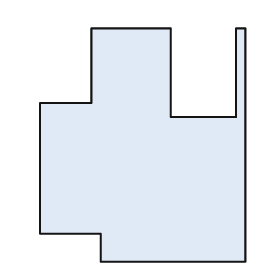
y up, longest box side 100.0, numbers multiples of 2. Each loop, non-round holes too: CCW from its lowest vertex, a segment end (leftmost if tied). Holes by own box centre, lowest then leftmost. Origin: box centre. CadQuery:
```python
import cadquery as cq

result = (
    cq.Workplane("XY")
    .moveTo(-18.0, -50.0)
    .lineTo(44.0, -50.0)
    .lineTo(44.0, 50.0)
    .lineTo(40.0, 50.0)
    .lineTo(40.0, 12.0)
    .lineTo(12.0, 12.0)
    .lineTo(12.0, 50.0)
    .lineTo(-22.0, 50.0)
    .lineTo(-22.0, 18.0)
    .lineTo(-44.0, 18.0)
    .lineTo(-44.0, -38.0)
    .lineTo(-18.0, -38.0)
    .close()
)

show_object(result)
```